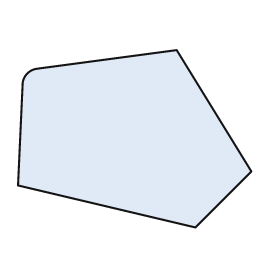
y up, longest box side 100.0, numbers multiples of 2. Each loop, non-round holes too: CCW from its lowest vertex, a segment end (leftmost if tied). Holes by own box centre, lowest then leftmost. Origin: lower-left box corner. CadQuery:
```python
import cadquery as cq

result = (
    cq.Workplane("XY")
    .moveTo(76.0, 0.0)
    .lineTo(100.0, 24.0)
    .lineTo(68.0, 76.0)
    .lineTo(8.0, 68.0)
    .threePointArc((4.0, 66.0), (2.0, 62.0))
    .lineTo(0.0, 18.0)
    .close()
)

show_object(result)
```